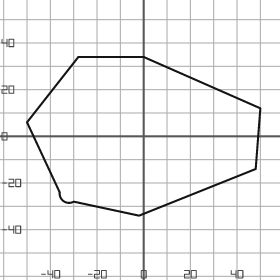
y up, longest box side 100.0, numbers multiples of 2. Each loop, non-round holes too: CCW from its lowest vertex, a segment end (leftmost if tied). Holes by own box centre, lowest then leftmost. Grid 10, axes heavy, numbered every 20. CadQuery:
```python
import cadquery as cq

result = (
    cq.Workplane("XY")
    .moveTo(-2.0, -34.0)
    .lineTo(48.0, -14.0)
    .lineTo(50.0, 12.0)
    .lineTo(0.0, 34.0)
    .lineTo(-28.0, 34.0)
    .lineTo(-50.0, 6.0)
    .lineTo(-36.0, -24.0)
    .threePointArc((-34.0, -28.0), (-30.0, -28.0))
    .close()
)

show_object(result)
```